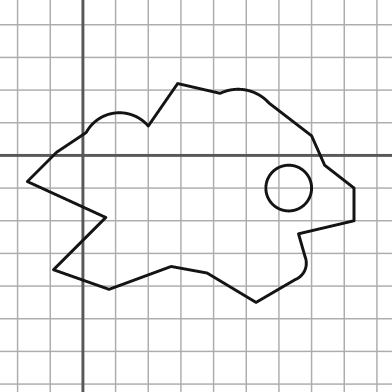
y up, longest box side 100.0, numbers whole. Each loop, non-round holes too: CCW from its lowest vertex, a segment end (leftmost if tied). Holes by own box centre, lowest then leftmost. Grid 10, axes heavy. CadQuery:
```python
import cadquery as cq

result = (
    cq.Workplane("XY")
    .moveTo(53.0, -45.0)
    .lineTo(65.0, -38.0)
    .threePointArc((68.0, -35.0), (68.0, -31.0))
    .lineTo(66.0, -24.0)
    .lineTo(83.0, -20.0)
    .lineTo(83.0, -10.0)
    .lineTo(74.0, -3.0)
    .lineTo(70.0, 6.0)
    .lineTo(57.0, 16.0)
    .threePointArc((50.0, 20.0), (42.0, 19.0))
    .lineTo(29.0, 22.0)
    .lineTo(20.0, 9.0)
    .threePointArc((10.0, 13.0), (1.0, 7.0))
    .lineTo(-8.0, 1.0)
    .lineTo(-17.0, -8.0)
    .lineTo(7.0, -19.0)
    .lineTo(-9.0, -35.0)
    .lineTo(8.0, -41.0)
    .lineTo(27.0, -34.0)
    .lineTo(38.0, -36.0)
    .close()
    .moveTo(63.0, -10.0)
    .circle(7.0)
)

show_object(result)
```